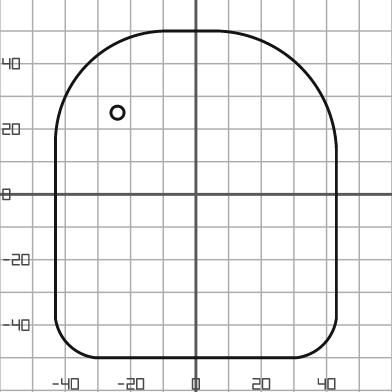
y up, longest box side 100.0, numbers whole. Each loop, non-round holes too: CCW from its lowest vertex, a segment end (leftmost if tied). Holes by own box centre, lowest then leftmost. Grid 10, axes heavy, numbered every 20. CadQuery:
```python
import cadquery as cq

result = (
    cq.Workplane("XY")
    .moveTo(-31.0, -50.0)
    .lineTo(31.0, -50.0)
    .threePointArc((39.0, -46.0), (43.0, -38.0))
    .lineTo(43.0, 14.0)
    .threePointArc((32.0, 39.0), (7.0, 50.0))
    .lineTo(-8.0, 50.0)
    .threePointArc((-33.0, 40.0), (-43.0, 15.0))
    .lineTo(-43.0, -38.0)
    .threePointArc((-39.0, -46.0), (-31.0, -50.0))
    .close()
    .moveTo(-24.0, 25.0)
    .circle(2.0)
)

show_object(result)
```